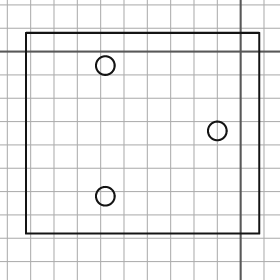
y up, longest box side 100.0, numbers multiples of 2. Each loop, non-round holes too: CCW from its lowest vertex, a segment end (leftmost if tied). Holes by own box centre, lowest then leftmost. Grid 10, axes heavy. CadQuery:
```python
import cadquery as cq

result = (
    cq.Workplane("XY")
    .moveTo(-92.0, -78.0)
    .lineTo(8.0, -78.0)
    .lineTo(8.0, 8.0)
    .lineTo(-92.0, 8.0)
    .close()
    .moveTo(-58.0, -62.0)
    .circle(4.0)
    .moveTo(-10.0, -34.0)
    .circle(4.0)
    .moveTo(-58.0, -6.0)
    .circle(4.0)
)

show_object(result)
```